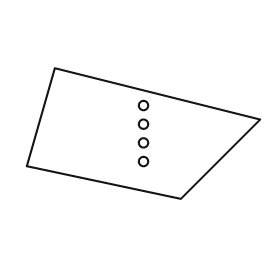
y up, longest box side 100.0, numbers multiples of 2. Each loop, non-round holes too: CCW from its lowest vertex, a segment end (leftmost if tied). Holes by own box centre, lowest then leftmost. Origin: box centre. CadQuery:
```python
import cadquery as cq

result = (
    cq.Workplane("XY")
    .moveTo(16.0, -28.0)
    .lineTo(50.0, 6.0)
    .lineTo(-38.0, 28.0)
    .lineTo(-50.0, -14.0)
    .close()
    .moveTo(0.0, -12.0)
    .circle(2.0)
    .moveTo(0.0, -4.0)
    .circle(2.0)
    .moveTo(0.0, 4.0)
    .circle(2.0)
    .moveTo(0.0, 12.0)
    .circle(2.0)
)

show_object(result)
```